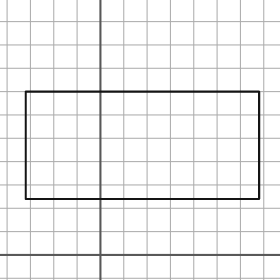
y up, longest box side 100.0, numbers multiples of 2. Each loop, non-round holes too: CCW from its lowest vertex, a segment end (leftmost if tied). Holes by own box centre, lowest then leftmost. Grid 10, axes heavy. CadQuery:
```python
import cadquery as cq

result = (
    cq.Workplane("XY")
    .moveTo(-32.0, 24.0)
    .lineTo(68.0, 24.0)
    .lineTo(68.0, 70.0)
    .lineTo(-32.0, 70.0)
    .close()
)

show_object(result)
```